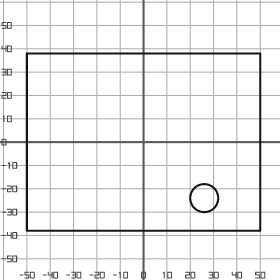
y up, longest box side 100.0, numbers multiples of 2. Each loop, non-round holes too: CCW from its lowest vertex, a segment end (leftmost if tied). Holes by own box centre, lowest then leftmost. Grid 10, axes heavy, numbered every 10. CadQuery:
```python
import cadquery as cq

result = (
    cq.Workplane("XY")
    .moveTo(-50.0, -38.0)
    .lineTo(50.0, -38.0)
    .lineTo(50.0, 38.0)
    .lineTo(-50.0, 38.0)
    .close()
    .moveTo(26.0, -24.0)
    .circle(6.0)
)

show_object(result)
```